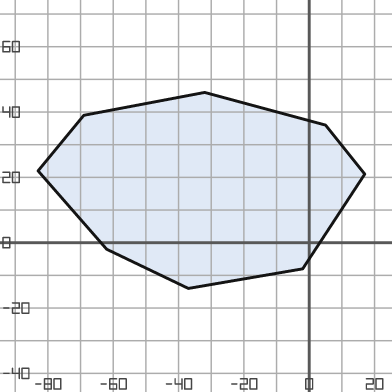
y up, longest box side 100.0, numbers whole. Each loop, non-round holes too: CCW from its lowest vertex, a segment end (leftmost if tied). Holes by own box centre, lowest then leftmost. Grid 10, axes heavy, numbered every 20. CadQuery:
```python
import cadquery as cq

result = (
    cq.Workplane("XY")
    .moveTo(-37.0, -14.0)
    .lineTo(-2.0, -8.0)
    .lineTo(17.0, 21.0)
    .lineTo(5.0, 36.0)
    .lineTo(-32.0, 46.0)
    .lineTo(-69.0, 39.0)
    .lineTo(-83.0, 22.0)
    .lineTo(-62.0, -2.0)
    .close()
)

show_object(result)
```